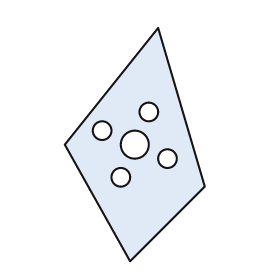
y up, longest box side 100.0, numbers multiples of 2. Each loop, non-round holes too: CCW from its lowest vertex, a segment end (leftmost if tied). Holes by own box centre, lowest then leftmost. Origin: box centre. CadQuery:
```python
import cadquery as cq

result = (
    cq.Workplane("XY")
    .moveTo(-2.0, -50.0)
    .lineTo(30.0, -18.0)
    .lineTo(10.0, 50.0)
    .lineTo(-30.0, 0.0)
    .close()
    .moveTo(-6.0, -14.0)
    .circle(4.0)
    .moveTo(14.0, -6.0)
    .circle(4.0)
    .moveTo(0.0, 0.0)
    .circle(6.0)
    .moveTo(-14.0, 6.0)
    .circle(4.0)
    .moveTo(6.0, 14.0)
    .circle(4.0)
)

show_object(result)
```